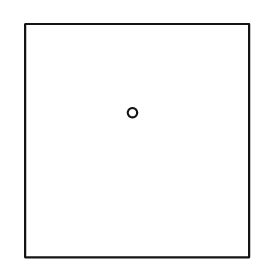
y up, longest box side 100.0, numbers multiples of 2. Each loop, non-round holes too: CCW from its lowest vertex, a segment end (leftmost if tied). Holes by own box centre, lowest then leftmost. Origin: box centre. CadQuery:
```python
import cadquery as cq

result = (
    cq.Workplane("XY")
    .moveTo(-48.0, -50.0)
    .lineTo(48.0, -50.0)
    .lineTo(48.0, 50.0)
    .lineTo(-48.0, 50.0)
    .close()
    .moveTo(-2.0, 12.0)
    .circle(2.0)
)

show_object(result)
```